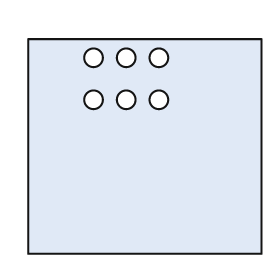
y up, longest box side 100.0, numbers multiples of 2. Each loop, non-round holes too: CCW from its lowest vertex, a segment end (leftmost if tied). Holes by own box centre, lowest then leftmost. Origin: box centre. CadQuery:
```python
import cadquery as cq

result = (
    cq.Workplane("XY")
    .moveTo(-50.0, -46.0)
    .lineTo(50.0, -46.0)
    .lineTo(50.0, 46.0)
    .lineTo(-50.0, 46.0)
    .close()
    .moveTo(-22.0, 20.0)
    .circle(4.0)
    .moveTo(-8.0, 20.0)
    .circle(4.0)
    .moveTo(6.0, 20.0)
    .circle(4.0)
    .moveTo(-22.0, 38.0)
    .circle(4.0)
    .moveTo(-8.0, 38.0)
    .circle(4.0)
    .moveTo(6.0, 38.0)
    .circle(4.0)
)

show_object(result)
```